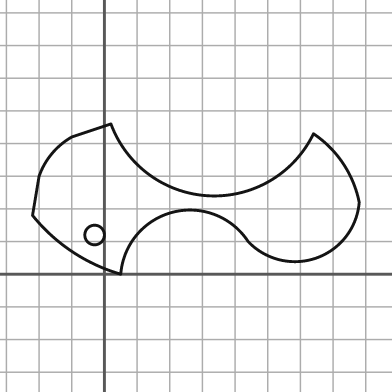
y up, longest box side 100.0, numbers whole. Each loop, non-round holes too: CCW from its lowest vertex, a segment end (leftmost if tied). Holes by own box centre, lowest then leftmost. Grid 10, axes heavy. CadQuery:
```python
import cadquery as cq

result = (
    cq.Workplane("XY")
    .moveTo(5.0, 0.0)
    .threePointArc((21.0, 19.0), (44.0, 10.0))
    .threePointArc((65.0, 5.0), (78.0, 22.0))
    .threePointArc((73.0, 34.0), (64.0, 43.0))
    .threePointArc((32.0, 24.0), (2.0, 46.0))
    .lineTo(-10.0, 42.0)
    .threePointArc((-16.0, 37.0), (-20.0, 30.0))
    .lineTo(-22.0, 18.0)
    .threePointArc((-10.0, 7.0), (5.0, 0.0))
    .close()
    .moveTo(-3.0, 12.0)
    .circle(3.0)
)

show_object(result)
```